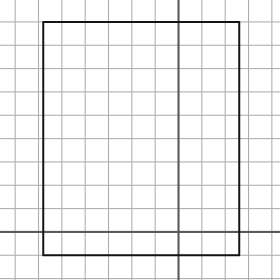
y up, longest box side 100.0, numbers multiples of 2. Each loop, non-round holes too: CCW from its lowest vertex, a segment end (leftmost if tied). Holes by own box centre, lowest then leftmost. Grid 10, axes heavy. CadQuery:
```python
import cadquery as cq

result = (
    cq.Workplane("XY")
    .moveTo(-58.0, -10.0)
    .lineTo(26.0, -10.0)
    .lineTo(26.0, 90.0)
    .lineTo(-58.0, 90.0)
    .close()
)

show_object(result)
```